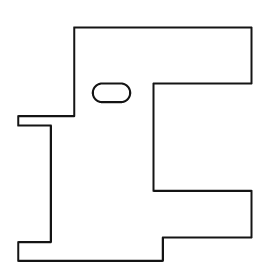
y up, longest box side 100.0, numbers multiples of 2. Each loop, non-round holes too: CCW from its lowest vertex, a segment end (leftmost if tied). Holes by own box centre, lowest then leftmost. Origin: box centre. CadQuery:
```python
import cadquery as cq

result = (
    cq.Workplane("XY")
    .moveTo(-50.0, -50.0)
    .lineTo(12.0, -50.0)
    .lineTo(12.0, -40.0)
    .lineTo(50.0, -40.0)
    .lineTo(50.0, -20.0)
    .lineTo(8.0, -20.0)
    .lineTo(8.0, 26.0)
    .lineTo(50.0, 26.0)
    .lineTo(50.0, 50.0)
    .lineTo(-26.0, 50.0)
    .lineTo(-26.0, 12.0)
    .lineTo(-50.0, 12.0)
    .lineTo(-50.0, 8.0)
    .lineTo(-36.0, 8.0)
    .lineTo(-36.0, -42.0)
    .lineTo(-50.0, -42.0)
    .close()
    .moveTo(-14.0, 18.0)
    .lineTo(-6.0, 18.0)
    .threePointArc((-2.0, 22.0), (-6.0, 26.0))
    .lineTo(-14.0, 26.0)
    .threePointArc((-18.0, 22.0), (-14.0, 18.0))
    .close()
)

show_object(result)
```